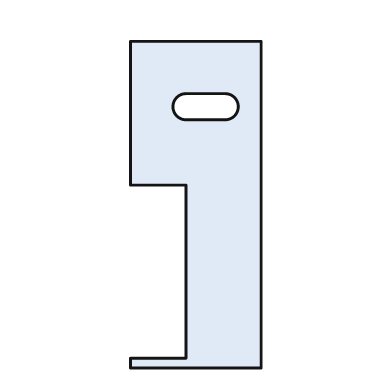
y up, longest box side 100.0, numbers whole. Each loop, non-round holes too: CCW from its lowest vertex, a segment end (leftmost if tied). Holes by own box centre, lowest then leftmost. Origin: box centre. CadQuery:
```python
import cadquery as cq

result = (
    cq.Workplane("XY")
    .moveTo(-20.0, -50.0)
    .lineTo(20.0, -50.0)
    .lineTo(20.0, 50.0)
    .lineTo(-20.0, 50.0)
    .lineTo(-20.0, 6.0)
    .lineTo(-3.0, 6.0)
    .lineTo(-3.0, -47.0)
    .lineTo(-20.0, -47.0)
    .close()
    .moveTo(-3.0, 26.0)
    .lineTo(9.0, 26.0)
    .threePointArc((13.0, 30.0), (9.0, 34.0))
    .lineTo(-3.0, 34.0)
    .threePointArc((-7.0, 30.0), (-3.0, 26.0))
    .close()
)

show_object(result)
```